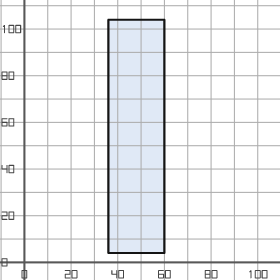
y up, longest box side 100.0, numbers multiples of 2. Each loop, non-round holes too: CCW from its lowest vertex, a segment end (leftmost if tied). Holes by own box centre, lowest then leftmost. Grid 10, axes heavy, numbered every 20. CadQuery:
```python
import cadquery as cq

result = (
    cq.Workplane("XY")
    .moveTo(36.0, 4.0)
    .lineTo(60.0, 4.0)
    .lineTo(60.0, 104.0)
    .lineTo(36.0, 104.0)
    .close()
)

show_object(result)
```